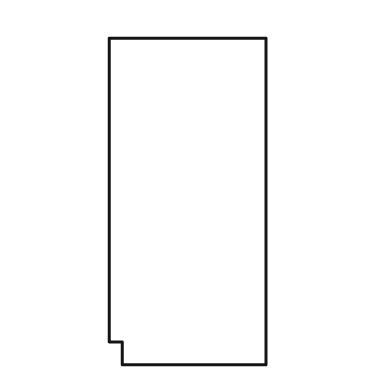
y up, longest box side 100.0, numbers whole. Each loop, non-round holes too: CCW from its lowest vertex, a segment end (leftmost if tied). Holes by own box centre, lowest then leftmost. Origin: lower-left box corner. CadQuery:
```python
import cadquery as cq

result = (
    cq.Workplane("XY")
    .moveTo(4.0, 0.0)
    .lineTo(48.0, 0.0)
    .lineTo(48.0, 100.0)
    .lineTo(0.0, 100.0)
    .lineTo(0.0, 7.0)
    .lineTo(4.0, 7.0)
    .close()
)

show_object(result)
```